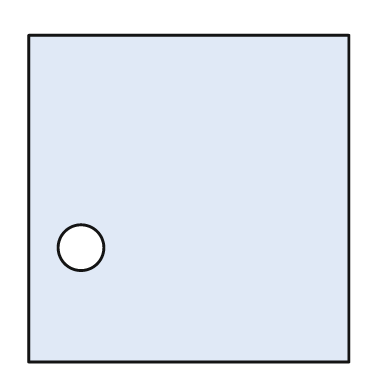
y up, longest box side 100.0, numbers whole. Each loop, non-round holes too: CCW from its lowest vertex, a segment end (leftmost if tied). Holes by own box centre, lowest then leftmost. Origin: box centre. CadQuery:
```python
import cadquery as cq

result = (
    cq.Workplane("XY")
    .moveTo(-49.0, -50.0)
    .lineTo(49.0, -50.0)
    .lineTo(49.0, 50.0)
    .lineTo(-49.0, 50.0)
    .close()
    .moveTo(-33.0, -15.0)
    .circle(7.0)
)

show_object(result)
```